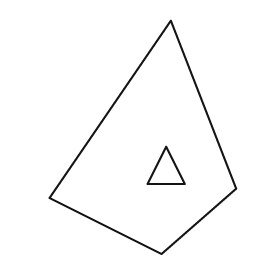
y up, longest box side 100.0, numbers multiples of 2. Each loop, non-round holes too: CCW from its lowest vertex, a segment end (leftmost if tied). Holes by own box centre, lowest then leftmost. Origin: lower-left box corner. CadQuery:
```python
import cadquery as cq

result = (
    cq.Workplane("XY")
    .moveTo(48.0, 0.0)
    .lineTo(80.0, 28.0)
    .lineTo(52.0, 100.0)
    .lineTo(0.0, 24.0)
    .close()
    .moveTo(42.0, 30.0)
    .lineTo(58.0, 30.0)
    .lineTo(50.0, 46.0)
    .close()
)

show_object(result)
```